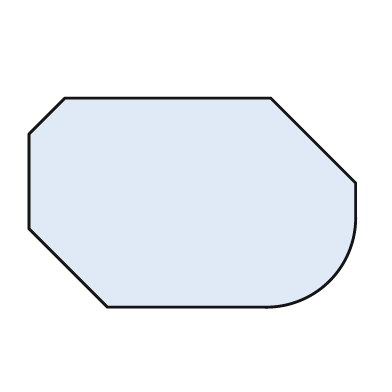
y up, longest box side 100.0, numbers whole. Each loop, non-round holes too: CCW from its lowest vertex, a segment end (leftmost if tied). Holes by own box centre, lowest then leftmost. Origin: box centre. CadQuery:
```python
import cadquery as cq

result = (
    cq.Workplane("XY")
    .moveTo(-26.0, -32.0)
    .lineTo(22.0, -32.0)
    .threePointArc((42.0, -24.0), (50.0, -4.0))
    .lineTo(50.0, 6.0)
    .lineTo(24.0, 32.0)
    .lineTo(-39.0, 32.0)
    .lineTo(-50.0, 21.0)
    .lineTo(-50.0, -8.0)
    .close()
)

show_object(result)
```